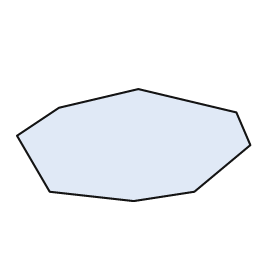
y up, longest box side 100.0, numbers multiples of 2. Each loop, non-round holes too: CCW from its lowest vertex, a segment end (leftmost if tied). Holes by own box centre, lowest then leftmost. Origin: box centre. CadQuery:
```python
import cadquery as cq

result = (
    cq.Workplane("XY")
    .moveTo(0.0, -24.0)
    .lineTo(26.0, -20.0)
    .lineTo(50.0, 0.0)
    .lineTo(44.0, 14.0)
    .lineTo(2.0, 24.0)
    .lineTo(-32.0, 16.0)
    .lineTo(-50.0, 4.0)
    .lineTo(-36.0, -20.0)
    .close()
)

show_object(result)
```